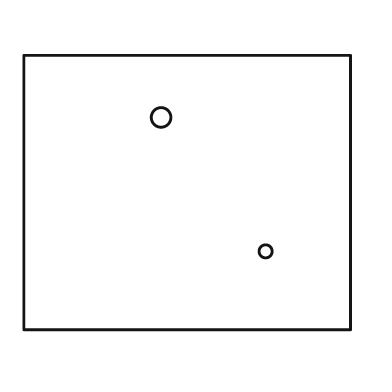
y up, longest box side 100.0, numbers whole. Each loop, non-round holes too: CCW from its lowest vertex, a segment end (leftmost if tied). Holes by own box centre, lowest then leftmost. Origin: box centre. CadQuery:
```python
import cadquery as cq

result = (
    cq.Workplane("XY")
    .moveTo(-50.0, -42.0)
    .lineTo(50.0, -42.0)
    .lineTo(50.0, 42.0)
    .lineTo(-50.0, 42.0)
    .close()
    .moveTo(24.0, -18.0)
    .circle(2.0)
    .moveTo(-8.0, 23.0)
    .circle(3.0)
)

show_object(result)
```